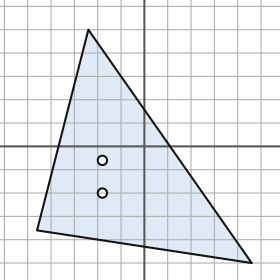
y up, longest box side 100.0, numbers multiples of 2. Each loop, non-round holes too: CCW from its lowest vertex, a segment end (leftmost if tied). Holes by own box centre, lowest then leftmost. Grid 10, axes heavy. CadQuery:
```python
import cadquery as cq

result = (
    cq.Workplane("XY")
    .moveTo(46.0, -50.0)
    .lineTo(-24.0, 50.0)
    .lineTo(-46.0, -36.0)
    .close()
    .moveTo(-18.0, -20.0)
    .circle(2.0)
    .moveTo(-18.0, -6.0)
    .circle(2.0)
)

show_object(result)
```